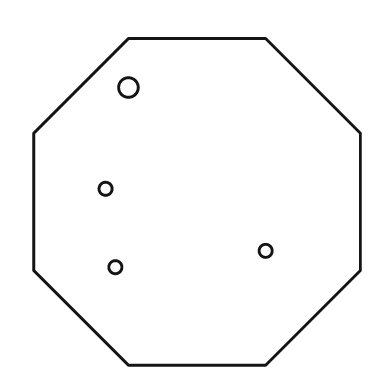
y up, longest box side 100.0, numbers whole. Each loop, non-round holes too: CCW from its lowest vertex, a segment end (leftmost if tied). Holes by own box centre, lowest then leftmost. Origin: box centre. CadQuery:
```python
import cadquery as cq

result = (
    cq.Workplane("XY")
    .moveTo(-21.0, -50.0)
    .lineTo(21.0, -50.0)
    .lineTo(50.0, -21.0)
    .lineTo(50.0, 21.0)
    .lineTo(21.0, 50.0)
    .lineTo(-21.0, 50.0)
    .lineTo(-50.0, 21.0)
    .lineTo(-50.0, -21.0)
    .close()
    .moveTo(-25.0, -20.0)
    .circle(2.0)
    .moveTo(21.0, -15.0)
    .circle(2.0)
    .moveTo(-28.0, 4.0)
    .circle(2.0)
    .moveTo(-21.0, 35.0)
    .circle(3.0)
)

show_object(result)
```